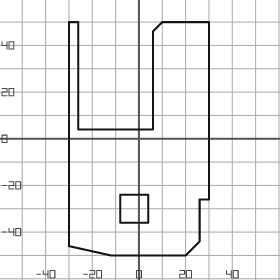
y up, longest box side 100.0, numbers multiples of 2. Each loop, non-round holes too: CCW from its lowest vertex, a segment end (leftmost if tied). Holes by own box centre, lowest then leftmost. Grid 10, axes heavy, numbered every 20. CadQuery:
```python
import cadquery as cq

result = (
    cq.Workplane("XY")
    .moveTo(-12.0, -50.0)
    .lineTo(20.0, -50.0)
    .lineTo(26.0, -44.0)
    .lineTo(26.0, -26.0)
    .lineTo(30.0, -26.0)
    .lineTo(30.0, 50.0)
    .lineTo(10.0, 50.0)
    .lineTo(6.0, 46.0)
    .lineTo(6.0, 4.0)
    .lineTo(-26.0, 4.0)
    .lineTo(-26.0, 50.0)
    .lineTo(-30.0, 50.0)
    .lineTo(-30.0, -46.0)
    .close()
    .moveTo(-8.0, -36.0)
    .lineTo(4.0, -36.0)
    .lineTo(4.0, -24.0)
    .lineTo(-8.0, -24.0)
    .close()
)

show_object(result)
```